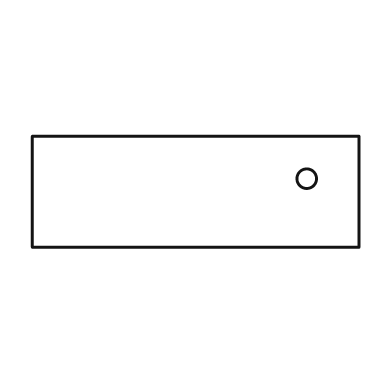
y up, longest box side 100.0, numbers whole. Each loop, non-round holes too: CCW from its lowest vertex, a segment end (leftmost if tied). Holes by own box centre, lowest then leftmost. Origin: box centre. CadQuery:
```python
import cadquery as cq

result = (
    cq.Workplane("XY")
    .moveTo(-50.0, -17.0)
    .lineTo(50.0, -17.0)
    .lineTo(50.0, 17.0)
    .lineTo(-50.0, 17.0)
    .close()
    .moveTo(34.0, 4.0)
    .circle(3.0)
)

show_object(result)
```